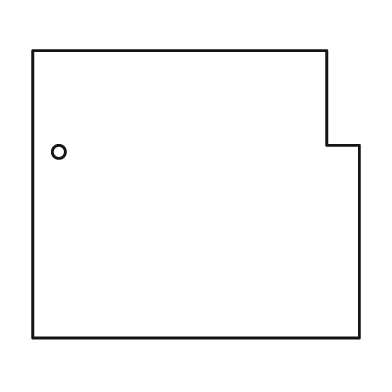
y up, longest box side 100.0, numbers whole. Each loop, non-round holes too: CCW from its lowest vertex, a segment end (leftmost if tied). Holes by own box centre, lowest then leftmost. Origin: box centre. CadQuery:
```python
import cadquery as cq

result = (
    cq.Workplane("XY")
    .moveTo(-50.0, -44.0)
    .lineTo(50.0, -44.0)
    .lineTo(50.0, 15.0)
    .lineTo(40.0, 15.0)
    .lineTo(40.0, 44.0)
    .lineTo(-50.0, 44.0)
    .close()
    .moveTo(-42.0, 13.0)
    .circle(2.0)
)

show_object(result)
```